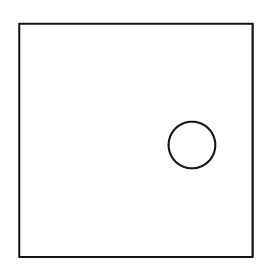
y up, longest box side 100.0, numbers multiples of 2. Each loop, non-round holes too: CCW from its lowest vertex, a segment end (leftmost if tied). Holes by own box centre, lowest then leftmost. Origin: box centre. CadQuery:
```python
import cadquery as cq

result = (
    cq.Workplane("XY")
    .moveTo(-50.0, -50.0)
    .lineTo(50.0, -50.0)
    .lineTo(50.0, 50.0)
    .lineTo(-50.0, 50.0)
    .close()
    .moveTo(24.0, -2.0)
    .circle(10.0)
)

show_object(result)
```